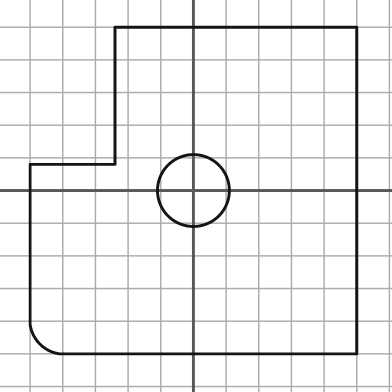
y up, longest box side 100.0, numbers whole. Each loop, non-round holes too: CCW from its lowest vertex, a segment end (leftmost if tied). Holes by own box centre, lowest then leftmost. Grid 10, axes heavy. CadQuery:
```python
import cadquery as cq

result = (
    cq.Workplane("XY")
    .moveTo(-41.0, -50.0)
    .lineTo(50.0, -50.0)
    .lineTo(50.0, 50.0)
    .lineTo(-24.0, 50.0)
    .lineTo(-24.0, 8.0)
    .lineTo(-50.0, 8.0)
    .lineTo(-50.0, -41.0)
    .threePointArc((-47.0, -47.0), (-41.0, -50.0))
    .close()
    .moveTo(0.0, 0.0)
    .circle(11.0)
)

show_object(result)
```